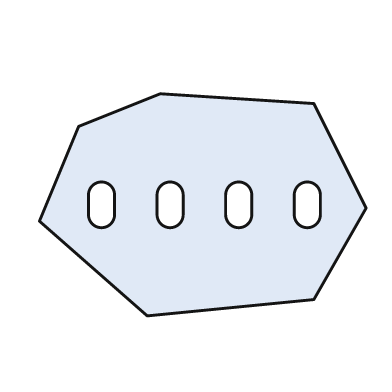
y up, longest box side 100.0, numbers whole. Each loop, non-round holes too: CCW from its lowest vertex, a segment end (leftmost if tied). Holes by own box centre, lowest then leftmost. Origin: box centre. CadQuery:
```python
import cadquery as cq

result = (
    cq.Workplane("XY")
    .moveTo(-17.0, -34.0)
    .lineTo(34.0, -29.0)
    .lineTo(50.0, -1.0)
    .lineTo(34.0, 31.0)
    .lineTo(-13.0, 34.0)
    .lineTo(-38.0, 24.0)
    .lineTo(-50.0, -5.0)
    .close()
    .moveTo(-35.0, -3.0)
    .threePointArc((-31.0, -7.0), (-27.0, -3.0))
    .lineTo(-27.0, 3.0)
    .threePointArc((-31.0, 7.0), (-35.0, 3.0))
    .close()
    .moveTo(-14.0, -3.0)
    .threePointArc((-10.0, -7.0), (-6.0, -3.0))
    .lineTo(-6.0, 3.0)
    .threePointArc((-10.0, 7.0), (-14.0, 3.0))
    .close()
    .moveTo(7.0, -3.0)
    .threePointArc((11.0, -7.0), (15.0, -3.0))
    .lineTo(15.0, 3.0)
    .threePointArc((11.0, 7.0), (7.0, 3.0))
    .close()
    .moveTo(28.0, -3.0)
    .threePointArc((32.0, -7.0), (36.0, -3.0))
    .lineTo(36.0, 3.0)
    .threePointArc((32.0, 7.0), (28.0, 3.0))
    .close()
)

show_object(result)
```